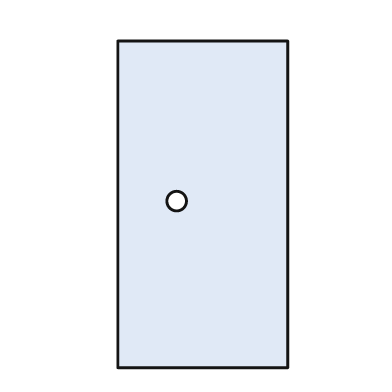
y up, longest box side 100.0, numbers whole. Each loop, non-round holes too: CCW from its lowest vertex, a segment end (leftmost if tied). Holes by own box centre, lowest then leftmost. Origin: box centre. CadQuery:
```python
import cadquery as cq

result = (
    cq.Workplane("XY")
    .moveTo(-26.0, -50.0)
    .lineTo(26.0, -50.0)
    .lineTo(26.0, 50.0)
    .lineTo(-26.0, 50.0)
    .close()
    .moveTo(-8.0, 1.0)
    .circle(3.0)
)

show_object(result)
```